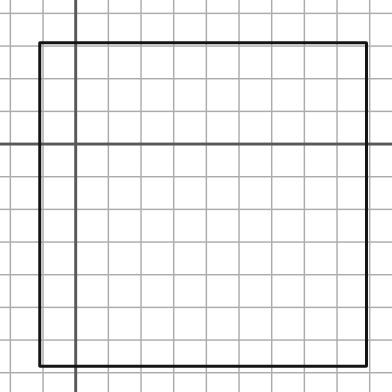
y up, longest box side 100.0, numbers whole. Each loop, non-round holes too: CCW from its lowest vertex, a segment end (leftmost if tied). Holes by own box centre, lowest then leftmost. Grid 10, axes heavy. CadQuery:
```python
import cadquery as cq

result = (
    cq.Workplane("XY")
    .moveTo(-11.0, -68.0)
    .lineTo(89.0, -68.0)
    .lineTo(89.0, 31.0)
    .lineTo(-11.0, 31.0)
    .close()
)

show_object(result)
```